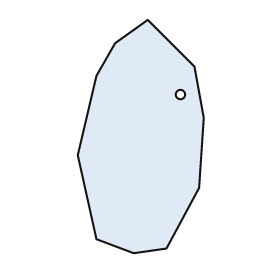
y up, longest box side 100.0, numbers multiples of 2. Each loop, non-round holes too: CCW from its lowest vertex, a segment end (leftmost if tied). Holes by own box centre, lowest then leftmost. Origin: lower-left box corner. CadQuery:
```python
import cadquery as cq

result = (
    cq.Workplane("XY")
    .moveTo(24.0, 0.0)
    .lineTo(38.0, 2.0)
    .lineTo(52.0, 28.0)
    .lineTo(54.0, 58.0)
    .lineTo(50.0, 80.0)
    .lineTo(30.0, 100.0)
    .lineTo(16.0, 90.0)
    .lineTo(8.0, 76.0)
    .lineTo(0.0, 42.0)
    .lineTo(8.0, 6.0)
    .close()
    .moveTo(44.0, 68.0)
    .circle(2.0)
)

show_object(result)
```